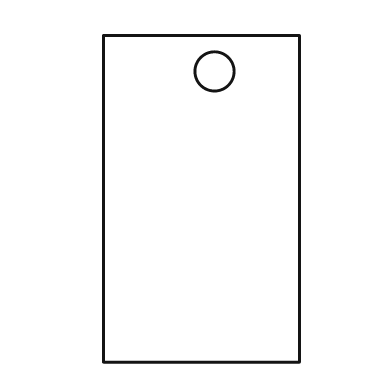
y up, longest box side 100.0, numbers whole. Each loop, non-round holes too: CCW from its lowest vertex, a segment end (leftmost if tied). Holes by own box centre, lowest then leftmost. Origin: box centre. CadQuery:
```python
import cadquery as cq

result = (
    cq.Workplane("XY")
    .moveTo(-30.0, -50.0)
    .lineTo(30.0, -50.0)
    .lineTo(30.0, 50.0)
    .lineTo(-30.0, 50.0)
    .close()
    .moveTo(4.0, 39.0)
    .circle(6.0)
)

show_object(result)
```